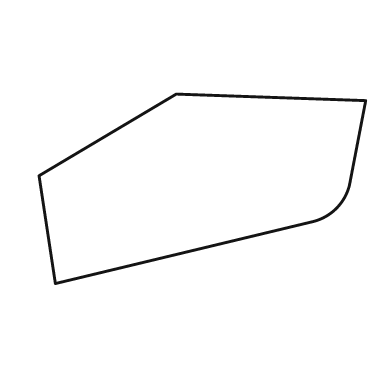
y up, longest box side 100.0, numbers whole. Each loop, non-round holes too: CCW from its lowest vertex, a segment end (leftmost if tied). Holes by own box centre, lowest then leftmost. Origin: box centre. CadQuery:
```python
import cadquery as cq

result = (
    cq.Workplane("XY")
    .moveTo(-45.0, -29.0)
    .lineTo(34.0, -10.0)
    .threePointArc((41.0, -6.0), (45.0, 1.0))
    .lineTo(50.0, 27.0)
    .lineTo(-8.0, 29.0)
    .lineTo(-50.0, 4.0)
    .close()
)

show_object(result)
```